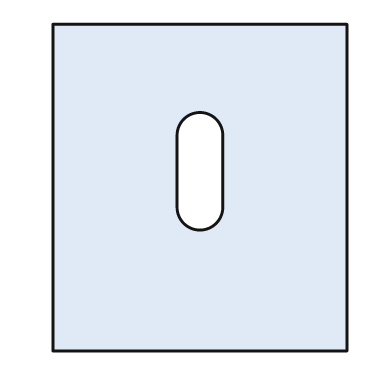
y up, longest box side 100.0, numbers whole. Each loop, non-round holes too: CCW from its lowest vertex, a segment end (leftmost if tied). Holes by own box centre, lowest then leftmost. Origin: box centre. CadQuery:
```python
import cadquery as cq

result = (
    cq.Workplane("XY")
    .moveTo(-45.0, -50.0)
    .lineTo(45.0, -50.0)
    .lineTo(45.0, 50.0)
    .lineTo(-45.0, 50.0)
    .close()
    .moveTo(-7.0, -6.0)
    .threePointArc((0.0, -13.0), (7.0, -6.0))
    .lineTo(7.0, 16.0)
    .threePointArc((0.0, 23.0), (-7.0, 16.0))
    .close()
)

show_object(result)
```